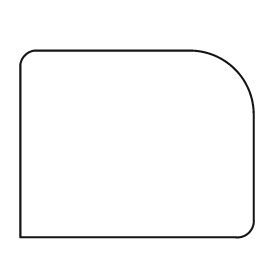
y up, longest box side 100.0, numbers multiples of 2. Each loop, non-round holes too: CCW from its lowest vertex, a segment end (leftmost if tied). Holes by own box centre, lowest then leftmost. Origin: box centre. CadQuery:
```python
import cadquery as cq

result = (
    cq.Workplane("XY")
    .moveTo(-50.0, -40.0)
    .lineTo(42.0, -40.0)
    .threePointArc((48.0, -38.0), (50.0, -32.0))
    .lineTo(50.0, 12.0)
    .threePointArc((42.0, 32.0), (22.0, 40.0))
    .lineTo(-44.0, 40.0)
    .threePointArc((-48.0, 38.0), (-50.0, 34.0))
    .close()
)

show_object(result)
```